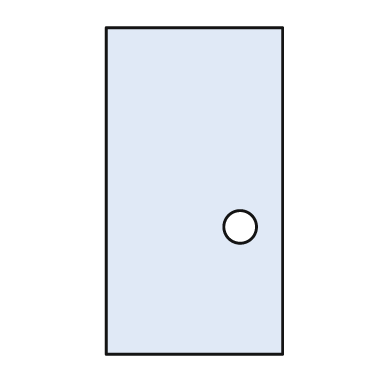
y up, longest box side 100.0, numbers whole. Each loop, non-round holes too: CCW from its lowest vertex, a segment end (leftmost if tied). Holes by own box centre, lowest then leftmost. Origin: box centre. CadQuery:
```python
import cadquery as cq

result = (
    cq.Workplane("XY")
    .moveTo(-27.0, -50.0)
    .lineTo(27.0, -50.0)
    .lineTo(27.0, 50.0)
    .lineTo(-27.0, 50.0)
    .close()
    .moveTo(14.0, -11.0)
    .circle(5.0)
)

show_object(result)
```